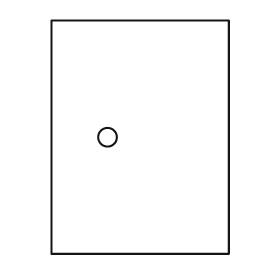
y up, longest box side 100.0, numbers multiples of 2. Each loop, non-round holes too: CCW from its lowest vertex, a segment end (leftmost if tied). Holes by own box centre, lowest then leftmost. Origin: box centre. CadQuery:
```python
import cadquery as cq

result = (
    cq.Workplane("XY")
    .moveTo(-38.0, -50.0)
    .lineTo(38.0, -50.0)
    .lineTo(38.0, 50.0)
    .lineTo(-38.0, 50.0)
    .close()
    .moveTo(-14.0, 0.0)
    .circle(4.0)
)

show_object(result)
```